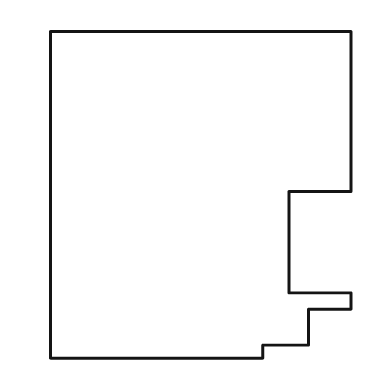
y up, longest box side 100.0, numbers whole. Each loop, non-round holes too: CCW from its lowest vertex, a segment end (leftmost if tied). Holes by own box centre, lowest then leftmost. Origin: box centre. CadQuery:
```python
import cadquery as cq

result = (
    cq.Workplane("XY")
    .moveTo(-46.0, -50.0)
    .lineTo(19.0, -50.0)
    .lineTo(19.0, -46.0)
    .lineTo(33.0, -46.0)
    .lineTo(33.0, -35.0)
    .lineTo(46.0, -35.0)
    .lineTo(46.0, -30.0)
    .lineTo(27.0, -30.0)
    .lineTo(27.0, 1.0)
    .lineTo(46.0, 1.0)
    .lineTo(46.0, 50.0)
    .lineTo(-46.0, 50.0)
    .close()
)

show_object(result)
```